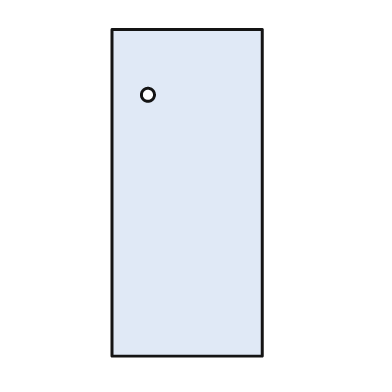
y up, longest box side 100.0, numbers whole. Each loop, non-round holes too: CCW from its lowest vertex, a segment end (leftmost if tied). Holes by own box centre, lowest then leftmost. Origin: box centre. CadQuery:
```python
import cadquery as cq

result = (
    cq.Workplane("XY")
    .moveTo(-23.0, -50.0)
    .lineTo(23.0, -50.0)
    .lineTo(23.0, 50.0)
    .lineTo(-23.0, 50.0)
    .close()
    .moveTo(-12.0, 30.0)
    .circle(2.0)
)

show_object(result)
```